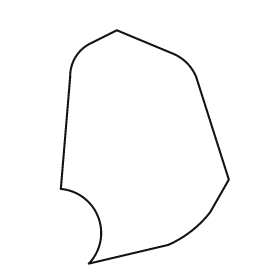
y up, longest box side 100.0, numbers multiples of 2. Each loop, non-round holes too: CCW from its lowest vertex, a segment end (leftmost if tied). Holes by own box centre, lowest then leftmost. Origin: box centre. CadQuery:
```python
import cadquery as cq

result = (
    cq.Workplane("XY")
    .moveTo(-24.0, -50.0)
    .lineTo(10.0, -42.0)
    .threePointArc((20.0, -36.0), (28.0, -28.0))
    .lineTo(36.0, -14.0)
    .lineTo(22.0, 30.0)
    .threePointArc((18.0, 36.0), (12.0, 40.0))
    .lineTo(-12.0, 50.0)
    .lineTo(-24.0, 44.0)
    .threePointArc((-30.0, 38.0), (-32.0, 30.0))
    .lineTo(-36.0, -18.0)
    .threePointArc((-20.0, -30.0), (-24.0, -50.0))
    .close()
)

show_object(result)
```